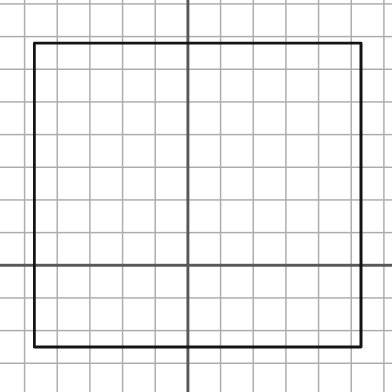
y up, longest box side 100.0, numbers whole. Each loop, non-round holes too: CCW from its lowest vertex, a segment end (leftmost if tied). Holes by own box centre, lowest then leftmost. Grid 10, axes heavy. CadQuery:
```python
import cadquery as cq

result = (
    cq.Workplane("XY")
    .moveTo(-47.0, -25.0)
    .lineTo(53.0, -25.0)
    .lineTo(53.0, 68.0)
    .lineTo(-47.0, 68.0)
    .close()
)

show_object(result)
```